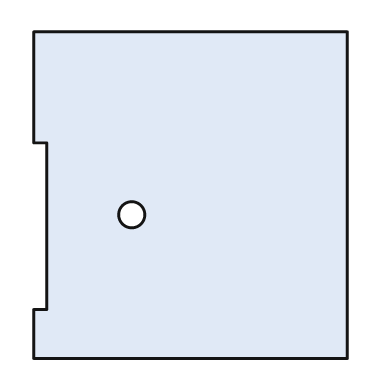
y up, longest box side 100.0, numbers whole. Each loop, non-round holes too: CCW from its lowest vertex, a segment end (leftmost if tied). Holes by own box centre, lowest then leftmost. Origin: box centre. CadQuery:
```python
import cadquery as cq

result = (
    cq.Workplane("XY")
    .moveTo(-48.0, -50.0)
    .lineTo(48.0, -50.0)
    .lineTo(48.0, 50.0)
    .lineTo(-48.0, 50.0)
    .lineTo(-48.0, 16.0)
    .lineTo(-44.0, 16.0)
    .lineTo(-44.0, -35.0)
    .lineTo(-48.0, -35.0)
    .close()
    .moveTo(-18.0, -6.0)
    .circle(4.0)
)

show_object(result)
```